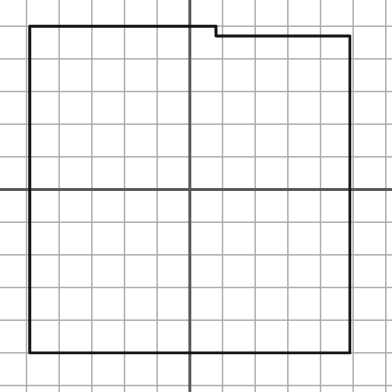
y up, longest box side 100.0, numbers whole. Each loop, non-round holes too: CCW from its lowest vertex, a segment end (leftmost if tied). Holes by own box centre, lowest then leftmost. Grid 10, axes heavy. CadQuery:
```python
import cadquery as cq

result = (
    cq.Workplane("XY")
    .moveTo(-49.0, -50.0)
    .lineTo(49.0, -50.0)
    .lineTo(49.0, 47.0)
    .lineTo(8.0, 47.0)
    .lineTo(8.0, 50.0)
    .lineTo(-49.0, 50.0)
    .close()
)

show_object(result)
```